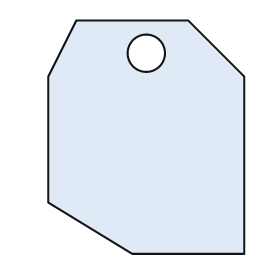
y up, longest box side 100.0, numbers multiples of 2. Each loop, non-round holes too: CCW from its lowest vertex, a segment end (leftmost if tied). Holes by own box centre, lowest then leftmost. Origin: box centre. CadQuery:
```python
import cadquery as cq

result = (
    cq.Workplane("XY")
    .moveTo(-6.0, -50.0)
    .lineTo(42.0, -50.0)
    .lineTo(42.0, 26.0)
    .lineTo(18.0, 50.0)
    .lineTo(-30.0, 50.0)
    .lineTo(-42.0, 26.0)
    .lineTo(-42.0, -28.0)
    .close()
    .moveTo(0.0, 36.0)
    .circle(8.0)
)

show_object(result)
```